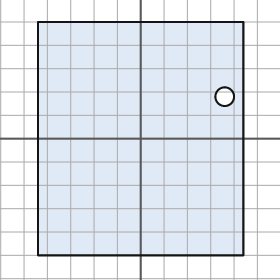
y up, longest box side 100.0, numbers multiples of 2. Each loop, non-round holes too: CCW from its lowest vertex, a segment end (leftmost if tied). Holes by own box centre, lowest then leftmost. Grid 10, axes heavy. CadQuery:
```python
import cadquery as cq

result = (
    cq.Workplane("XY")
    .moveTo(-44.0, -50.0)
    .lineTo(44.0, -50.0)
    .lineTo(44.0, 50.0)
    .lineTo(-44.0, 50.0)
    .close()
    .moveTo(36.0, 18.0)
    .circle(4.0)
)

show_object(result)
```